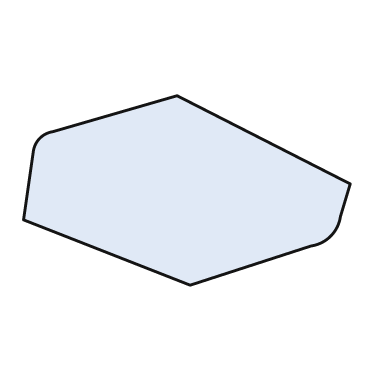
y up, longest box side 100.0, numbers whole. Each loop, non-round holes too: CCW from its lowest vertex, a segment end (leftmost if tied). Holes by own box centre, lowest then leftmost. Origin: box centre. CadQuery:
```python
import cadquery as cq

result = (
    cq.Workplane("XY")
    .moveTo(1.0, -29.0)
    .lineTo(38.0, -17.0)
    .threePointArc((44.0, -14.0), (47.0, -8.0))
    .lineTo(50.0, 2.0)
    .lineTo(-3.0, 29.0)
    .lineTo(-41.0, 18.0)
    .threePointArc((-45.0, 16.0), (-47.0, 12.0))
    .lineTo(-50.0, -9.0)
    .close()
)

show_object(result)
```